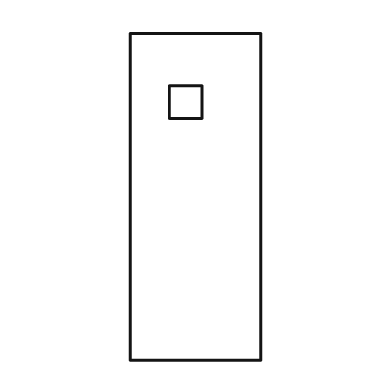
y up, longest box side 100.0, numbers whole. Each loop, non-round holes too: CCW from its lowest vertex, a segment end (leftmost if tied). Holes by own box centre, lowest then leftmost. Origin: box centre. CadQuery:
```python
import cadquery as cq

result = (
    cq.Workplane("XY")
    .moveTo(-20.0, -50.0)
    .lineTo(20.0, -50.0)
    .lineTo(20.0, 50.0)
    .lineTo(-20.0, 50.0)
    .close()
    .moveTo(-8.0, 24.0)
    .lineTo(2.0, 24.0)
    .lineTo(2.0, 34.0)
    .lineTo(-8.0, 34.0)
    .close()
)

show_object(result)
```